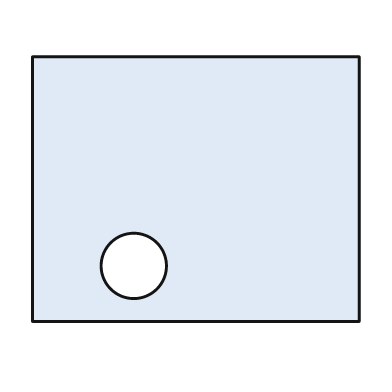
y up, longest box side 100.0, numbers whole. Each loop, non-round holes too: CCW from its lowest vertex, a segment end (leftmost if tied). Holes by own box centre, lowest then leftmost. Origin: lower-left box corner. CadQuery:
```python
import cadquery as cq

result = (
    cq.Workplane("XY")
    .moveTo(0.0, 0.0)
    .lineTo(100.0, 0.0)
    .lineTo(100.0, 81.0)
    .lineTo(0.0, 81.0)
    .close()
    .moveTo(31.0, 17.0)
    .circle(10.0)
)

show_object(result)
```